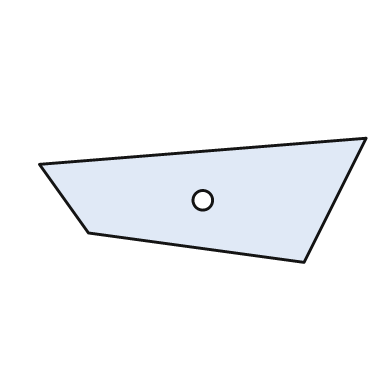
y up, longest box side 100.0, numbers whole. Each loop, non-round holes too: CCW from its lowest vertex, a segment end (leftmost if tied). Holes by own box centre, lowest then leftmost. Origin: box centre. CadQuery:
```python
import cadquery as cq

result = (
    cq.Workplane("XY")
    .moveTo(31.0, -19.0)
    .lineTo(50.0, 19.0)
    .lineTo(-50.0, 11.0)
    .lineTo(-35.0, -10.0)
    .close()
    .moveTo(0.0, 0.0)
    .circle(3.0)
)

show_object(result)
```